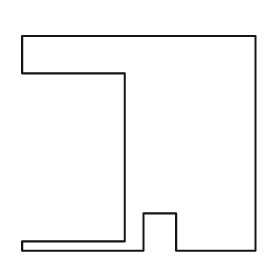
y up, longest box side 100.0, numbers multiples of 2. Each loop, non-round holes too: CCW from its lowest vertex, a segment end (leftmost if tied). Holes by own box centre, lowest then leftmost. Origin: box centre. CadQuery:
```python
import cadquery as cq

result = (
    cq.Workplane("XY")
    .moveTo(-50.0, -46.0)
    .lineTo(2.0, -46.0)
    .lineTo(2.0, -30.0)
    .lineTo(16.0, -30.0)
    .lineTo(16.0, -46.0)
    .lineTo(50.0, -46.0)
    .lineTo(50.0, 46.0)
    .lineTo(-50.0, 46.0)
    .lineTo(-50.0, 30.0)
    .lineTo(-6.0, 30.0)
    .lineTo(-6.0, -42.0)
    .lineTo(-50.0, -42.0)
    .close()
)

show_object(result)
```